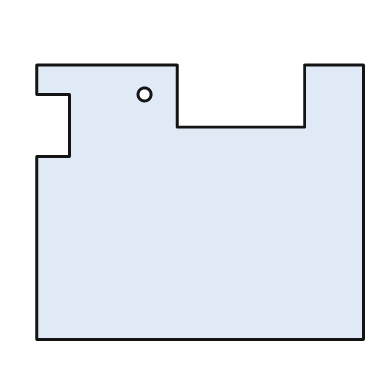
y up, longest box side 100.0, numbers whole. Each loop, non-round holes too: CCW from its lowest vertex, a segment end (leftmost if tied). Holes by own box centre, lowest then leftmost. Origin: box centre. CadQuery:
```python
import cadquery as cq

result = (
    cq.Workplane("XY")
    .moveTo(-50.0, -42.0)
    .lineTo(50.0, -42.0)
    .lineTo(50.0, 42.0)
    .lineTo(32.0, 42.0)
    .lineTo(32.0, 23.0)
    .lineTo(-7.0, 23.0)
    .lineTo(-7.0, 42.0)
    .lineTo(-50.0, 42.0)
    .lineTo(-50.0, 33.0)
    .lineTo(-40.0, 33.0)
    .lineTo(-40.0, 14.0)
    .lineTo(-50.0, 14.0)
    .close()
    .moveTo(-17.0, 33.0)
    .circle(2.0)
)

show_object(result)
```